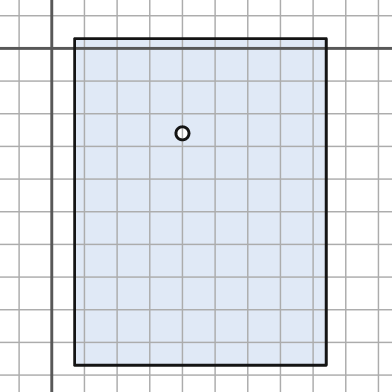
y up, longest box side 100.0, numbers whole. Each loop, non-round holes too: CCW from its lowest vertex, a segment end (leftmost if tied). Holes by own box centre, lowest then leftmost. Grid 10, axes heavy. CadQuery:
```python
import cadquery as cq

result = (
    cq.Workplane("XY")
    .moveTo(7.0, -97.0)
    .lineTo(84.0, -97.0)
    .lineTo(84.0, 3.0)
    .lineTo(7.0, 3.0)
    .close()
    .moveTo(40.0, -26.0)
    .circle(2.0)
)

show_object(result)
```